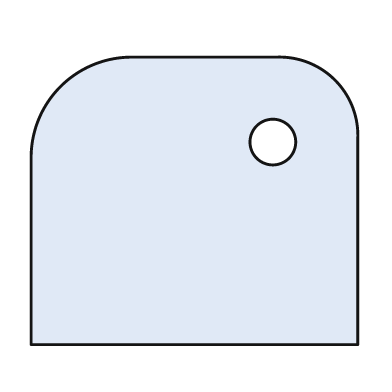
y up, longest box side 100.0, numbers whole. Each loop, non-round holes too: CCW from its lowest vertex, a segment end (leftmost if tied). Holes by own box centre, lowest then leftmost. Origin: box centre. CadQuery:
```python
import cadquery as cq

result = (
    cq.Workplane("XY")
    .moveTo(-50.0, -44.0)
    .lineTo(50.0, -44.0)
    .lineTo(50.0, 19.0)
    .threePointArc((43.0, 37.0), (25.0, 44.0))
    .lineTo(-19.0, 44.0)
    .threePointArc((-41.0, 35.0), (-50.0, 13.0))
    .close()
    .moveTo(24.0, 18.0)
    .circle(7.0)
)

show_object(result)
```